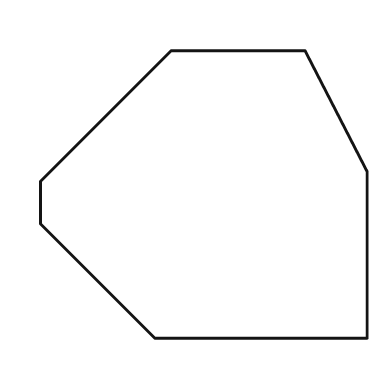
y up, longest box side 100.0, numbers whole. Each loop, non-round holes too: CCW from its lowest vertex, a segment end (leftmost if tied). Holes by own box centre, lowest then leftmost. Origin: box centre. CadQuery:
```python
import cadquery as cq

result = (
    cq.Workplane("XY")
    .moveTo(-15.0, -44.0)
    .lineTo(50.0, -44.0)
    .lineTo(50.0, 7.0)
    .lineTo(31.0, 44.0)
    .lineTo(-10.0, 44.0)
    .lineTo(-50.0, 4.0)
    .lineTo(-50.0, -9.0)
    .close()
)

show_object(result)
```